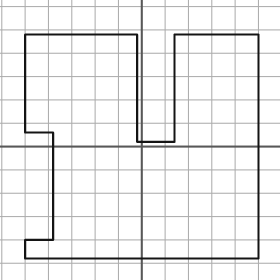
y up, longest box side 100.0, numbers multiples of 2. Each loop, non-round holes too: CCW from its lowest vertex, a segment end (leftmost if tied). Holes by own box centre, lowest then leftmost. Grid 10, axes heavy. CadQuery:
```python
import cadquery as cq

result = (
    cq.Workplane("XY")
    .moveTo(-50.0, -48.0)
    .lineTo(50.0, -48.0)
    .lineTo(50.0, 48.0)
    .lineTo(14.0, 48.0)
    .lineTo(14.0, 2.0)
    .lineTo(-2.0, 2.0)
    .lineTo(-2.0, 48.0)
    .lineTo(-50.0, 48.0)
    .lineTo(-50.0, 6.0)
    .lineTo(-38.0, 6.0)
    .lineTo(-38.0, -40.0)
    .lineTo(-50.0, -40.0)
    .close()
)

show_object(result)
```